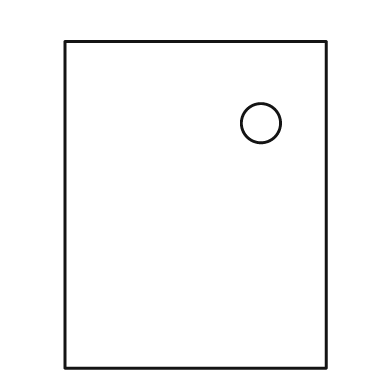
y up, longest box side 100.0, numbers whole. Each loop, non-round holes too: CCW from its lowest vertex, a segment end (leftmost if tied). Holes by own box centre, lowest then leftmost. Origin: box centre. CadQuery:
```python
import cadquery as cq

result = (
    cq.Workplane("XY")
    .moveTo(-40.0, -50.0)
    .lineTo(40.0, -50.0)
    .lineTo(40.0, 50.0)
    .lineTo(-40.0, 50.0)
    .close()
    .moveTo(20.0, 25.0)
    .circle(6.0)
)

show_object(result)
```